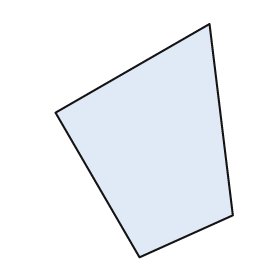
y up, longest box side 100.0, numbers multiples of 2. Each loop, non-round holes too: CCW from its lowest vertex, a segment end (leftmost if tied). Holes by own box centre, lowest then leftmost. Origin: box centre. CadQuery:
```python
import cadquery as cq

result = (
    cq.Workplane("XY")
    .moveTo(-2.0, -50.0)
    .lineTo(38.0, -32.0)
    .lineTo(28.0, 50.0)
    .lineTo(-38.0, 12.0)
    .close()
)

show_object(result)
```